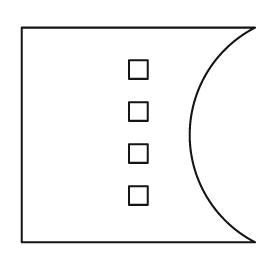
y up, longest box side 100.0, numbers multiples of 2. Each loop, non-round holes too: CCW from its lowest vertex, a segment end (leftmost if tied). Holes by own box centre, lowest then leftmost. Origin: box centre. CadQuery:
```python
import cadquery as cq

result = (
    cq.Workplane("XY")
    .moveTo(-50.0, -46.0)
    .lineTo(50.0, -46.0)
    .threePointArc((22.0, 0.0), (50.0, 46.0))
    .lineTo(-50.0, 46.0)
    .close()
    .moveTo(-4.0, -30.0)
    .lineTo(4.0, -30.0)
    .lineTo(4.0, -22.0)
    .lineTo(-4.0, -22.0)
    .close()
    .moveTo(-4.0, -12.0)
    .lineTo(4.0, -12.0)
    .lineTo(4.0, -4.0)
    .lineTo(-4.0, -4.0)
    .close()
    .moveTo(-4.0, 6.0)
    .lineTo(4.0, 6.0)
    .lineTo(4.0, 14.0)
    .lineTo(-4.0, 14.0)
    .close()
    .moveTo(-4.0, 24.0)
    .lineTo(4.0, 24.0)
    .lineTo(4.0, 32.0)
    .lineTo(-4.0, 32.0)
    .close()
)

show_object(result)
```